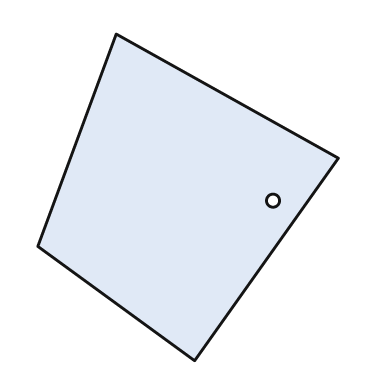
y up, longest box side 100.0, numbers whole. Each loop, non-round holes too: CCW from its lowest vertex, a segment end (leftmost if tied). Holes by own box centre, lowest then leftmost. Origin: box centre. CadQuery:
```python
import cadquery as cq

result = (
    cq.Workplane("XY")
    .moveTo(2.0, -50.0)
    .lineTo(46.0, 12.0)
    .lineTo(-22.0, 50.0)
    .lineTo(-46.0, -15.0)
    .close()
    .moveTo(26.0, -1.0)
    .circle(2.0)
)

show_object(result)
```